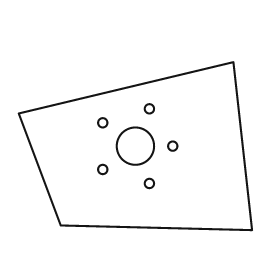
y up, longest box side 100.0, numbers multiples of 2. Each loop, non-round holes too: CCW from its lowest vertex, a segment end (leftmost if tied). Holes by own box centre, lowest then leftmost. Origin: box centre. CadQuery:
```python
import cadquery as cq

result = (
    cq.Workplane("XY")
    .moveTo(50.0, -36.0)
    .lineTo(42.0, 36.0)
    .lineTo(-50.0, 14.0)
    .lineTo(-32.0, -34.0)
    .close()
    .moveTo(6.0, -16.0)
    .circle(2.0)
    .moveTo(-14.0, -10.0)
    .circle(2.0)
    .moveTo(0.0, 0.0)
    .circle(8.0)
    .moveTo(16.0, 0.0)
    .circle(2.0)
    .moveTo(-14.0, 10.0)
    .circle(2.0)
    .moveTo(6.0, 16.0)
    .circle(2.0)
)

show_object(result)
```